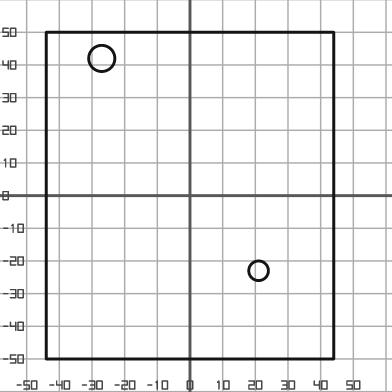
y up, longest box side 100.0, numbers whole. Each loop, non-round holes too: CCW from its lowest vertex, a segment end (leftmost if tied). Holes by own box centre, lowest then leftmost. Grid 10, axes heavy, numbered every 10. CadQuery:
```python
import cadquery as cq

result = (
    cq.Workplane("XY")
    .moveTo(-44.0, -50.0)
    .lineTo(44.0, -50.0)
    .lineTo(44.0, 50.0)
    .lineTo(-44.0, 50.0)
    .close()
    .moveTo(21.0, -23.0)
    .circle(3.0)
    .moveTo(-27.0, 42.0)
    .circle(4.0)
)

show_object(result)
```